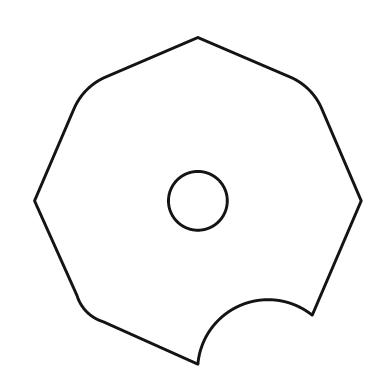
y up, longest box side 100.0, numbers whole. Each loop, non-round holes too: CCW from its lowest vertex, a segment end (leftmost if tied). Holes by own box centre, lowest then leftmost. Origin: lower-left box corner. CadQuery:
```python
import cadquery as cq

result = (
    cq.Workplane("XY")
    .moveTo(50.0, 0.0)
    .threePointArc((63.0, 18.0), (85.0, 15.0))
    .lineTo(100.0, 50.0)
    .lineTo(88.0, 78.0)
    .threePointArc((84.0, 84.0), (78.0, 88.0))
    .lineTo(50.0, 100.0)
    .lineTo(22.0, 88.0)
    .threePointArc((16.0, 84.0), (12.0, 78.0))
    .lineTo(0.0, 50.0)
    .lineTo(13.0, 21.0)
    .threePointArc((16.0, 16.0), (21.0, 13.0))
    .close()
    .moveTo(50.0, 50.0)
    .circle(9.0)
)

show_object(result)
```